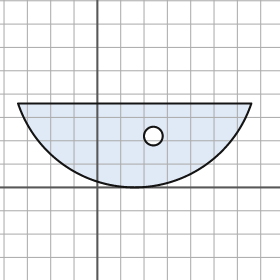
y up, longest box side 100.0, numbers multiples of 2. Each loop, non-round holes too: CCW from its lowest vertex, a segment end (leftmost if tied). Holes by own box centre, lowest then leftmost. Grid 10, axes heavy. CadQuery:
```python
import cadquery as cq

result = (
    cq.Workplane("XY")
    .moveTo(-34.0, 36.0)
    .threePointArc((16.0, 0.0), (66.0, 36.0))
    .close()
    .moveTo(24.0, 22.0)
    .circle(4.0)
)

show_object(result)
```